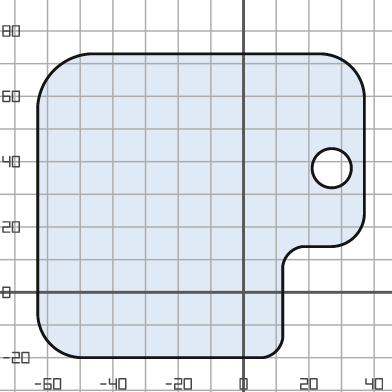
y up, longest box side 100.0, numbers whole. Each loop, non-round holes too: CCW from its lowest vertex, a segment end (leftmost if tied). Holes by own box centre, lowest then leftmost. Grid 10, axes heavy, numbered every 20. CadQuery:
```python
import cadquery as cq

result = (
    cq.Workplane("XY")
    .moveTo(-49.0, -20.0)
    .lineTo(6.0, -20.0)
    .threePointArc((10.0, -18.0), (12.0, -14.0))
    .lineTo(12.0, 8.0)
    .threePointArc((14.0, 12.0), (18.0, 14.0))
    .lineTo(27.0, 14.0)
    .threePointArc((34.0, 17.0), (37.0, 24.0))
    .lineTo(37.0, 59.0)
    .threePointArc((33.0, 69.0), (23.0, 73.0))
    .lineTo(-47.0, 73.0)
    .threePointArc((-58.0, 68.0), (-63.0, 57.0))
    .lineTo(-63.0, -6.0)
    .threePointArc((-59.0, -16.0), (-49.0, -20.0))
    .close()
    .moveTo(27.0, 38.0)
    .circle(6.0)
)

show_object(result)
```